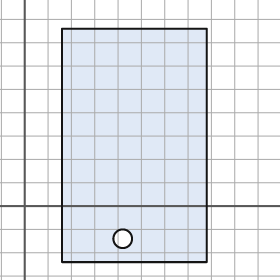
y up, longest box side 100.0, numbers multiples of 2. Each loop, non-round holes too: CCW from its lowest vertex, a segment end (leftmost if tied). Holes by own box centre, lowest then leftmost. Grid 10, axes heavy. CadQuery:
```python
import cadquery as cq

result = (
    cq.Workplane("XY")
    .moveTo(16.0, -24.0)
    .lineTo(78.0, -24.0)
    .lineTo(78.0, 76.0)
    .lineTo(16.0, 76.0)
    .close()
    .moveTo(42.0, -14.0)
    .circle(4.0)
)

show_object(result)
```